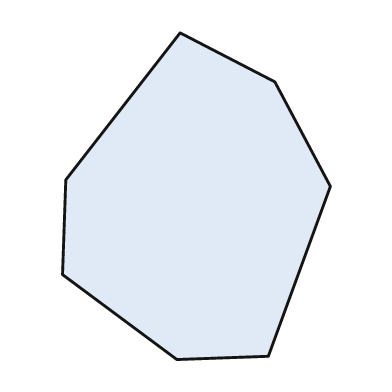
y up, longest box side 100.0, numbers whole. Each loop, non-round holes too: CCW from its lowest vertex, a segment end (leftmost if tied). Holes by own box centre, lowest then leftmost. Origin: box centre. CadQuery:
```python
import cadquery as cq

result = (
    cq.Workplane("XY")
    .moveTo(-6.0, -50.0)
    .lineTo(22.0, -49.0)
    .lineTo(41.0, 3.0)
    .lineTo(24.0, 35.0)
    .lineTo(-5.0, 50.0)
    .lineTo(-40.0, 5.0)
    .lineTo(-41.0, -24.0)
    .close()
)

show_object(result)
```